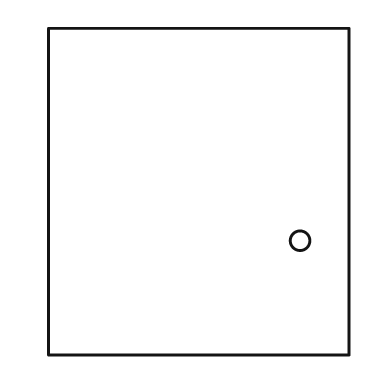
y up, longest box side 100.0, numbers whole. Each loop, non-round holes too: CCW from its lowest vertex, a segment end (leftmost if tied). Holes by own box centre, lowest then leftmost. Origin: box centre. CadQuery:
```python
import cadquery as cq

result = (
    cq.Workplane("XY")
    .moveTo(-46.0, -50.0)
    .lineTo(46.0, -50.0)
    .lineTo(46.0, 50.0)
    .lineTo(-46.0, 50.0)
    .close()
    .moveTo(31.0, -15.0)
    .circle(3.0)
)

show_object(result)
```